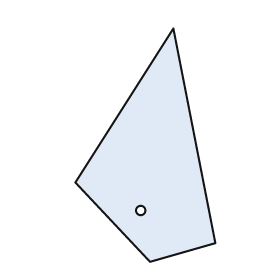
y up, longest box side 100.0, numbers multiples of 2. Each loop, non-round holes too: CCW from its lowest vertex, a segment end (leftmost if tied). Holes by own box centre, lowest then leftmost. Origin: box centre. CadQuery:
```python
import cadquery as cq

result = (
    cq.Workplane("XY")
    .moveTo(2.0, -50.0)
    .lineTo(30.0, -42.0)
    .lineTo(12.0, 50.0)
    .lineTo(-30.0, -16.0)
    .close()
    .moveTo(-2.0, -28.0)
    .circle(2.0)
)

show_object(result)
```